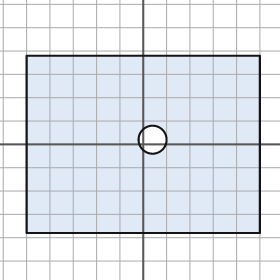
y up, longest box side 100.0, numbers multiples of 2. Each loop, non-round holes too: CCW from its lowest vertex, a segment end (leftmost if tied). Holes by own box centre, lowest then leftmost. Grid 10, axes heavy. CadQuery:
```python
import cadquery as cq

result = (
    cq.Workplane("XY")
    .moveTo(-50.0, -38.0)
    .lineTo(50.0, -38.0)
    .lineTo(50.0, 38.0)
    .lineTo(-50.0, 38.0)
    .close()
    .moveTo(4.0, 2.0)
    .circle(6.0)
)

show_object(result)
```